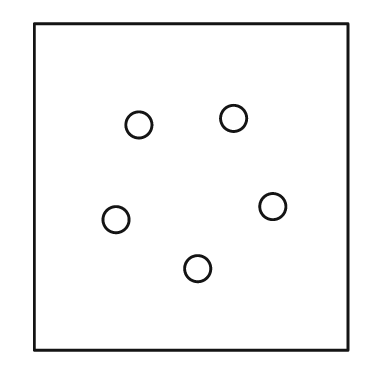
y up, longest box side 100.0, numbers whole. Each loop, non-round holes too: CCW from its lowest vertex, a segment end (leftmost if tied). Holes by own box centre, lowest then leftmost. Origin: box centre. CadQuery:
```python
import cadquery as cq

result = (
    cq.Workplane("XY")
    .moveTo(-48.0, -50.0)
    .lineTo(48.0, -50.0)
    .lineTo(48.0, 50.0)
    .lineTo(-48.0, 50.0)
    .close()
    .moveTo(2.0, -25.0)
    .circle(4.0)
    .moveTo(-23.0, -10.0)
    .circle(4.0)
    .moveTo(25.0, -6.0)
    .circle(4.0)
    .moveTo(-16.0, 19.0)
    .circle(4.0)
    .moveTo(13.0, 21.0)
    .circle(4.0)
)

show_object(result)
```